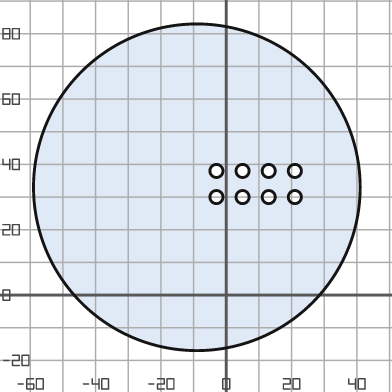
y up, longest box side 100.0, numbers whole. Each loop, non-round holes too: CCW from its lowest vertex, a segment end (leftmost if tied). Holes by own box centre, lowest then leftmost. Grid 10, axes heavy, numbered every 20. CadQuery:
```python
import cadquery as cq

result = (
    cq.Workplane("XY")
    .moveTo(-9.0, 33.0)
    .circle(50.0)
    .moveTo(-3.0, 30.0)
    .circle(2.0)
    .moveTo(5.0, 30.0)
    .circle(2.0)
    .moveTo(13.0, 30.0)
    .circle(2.0)
    .moveTo(21.0, 30.0)
    .circle(2.0)
    .moveTo(-3.0, 38.0)
    .circle(2.0)
    .moveTo(5.0, 38.0)
    .circle(2.0)
    .moveTo(13.0, 38.0)
    .circle(2.0)
    .moveTo(21.0, 38.0)
    .circle(2.0)
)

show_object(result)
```